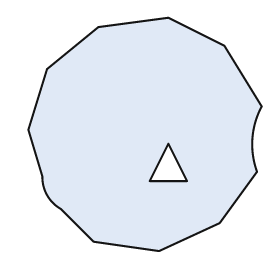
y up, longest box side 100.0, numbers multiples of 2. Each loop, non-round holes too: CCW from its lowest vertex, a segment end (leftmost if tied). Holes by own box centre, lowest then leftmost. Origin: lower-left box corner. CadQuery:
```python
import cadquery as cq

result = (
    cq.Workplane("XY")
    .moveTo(56.0, 0.0)
    .lineTo(82.0, 12.0)
    .lineTo(98.0, 34.0)
    .threePointArc((96.0, 48.0), (100.0, 62.0))
    .lineTo(84.0, 88.0)
    .lineTo(60.0, 100.0)
    .lineTo(30.0, 96.0)
    .lineTo(8.0, 78.0)
    .lineTo(0.0, 52.0)
    .lineTo(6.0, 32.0)
    .threePointArc((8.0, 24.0), (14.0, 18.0))
    .lineTo(28.0, 4.0)
    .close()
    .moveTo(52.0, 30.0)
    .lineTo(68.0, 30.0)
    .lineTo(60.0, 46.0)
    .close()
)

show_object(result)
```